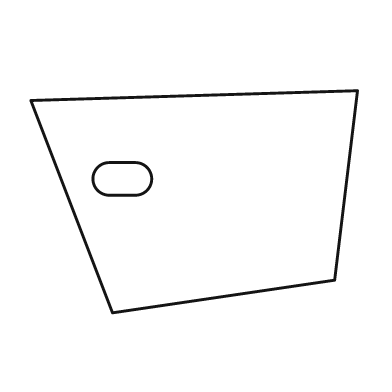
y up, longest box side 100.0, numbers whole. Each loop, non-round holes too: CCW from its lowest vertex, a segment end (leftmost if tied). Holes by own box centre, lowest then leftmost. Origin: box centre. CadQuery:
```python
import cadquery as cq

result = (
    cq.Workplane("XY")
    .moveTo(-25.0, -34.0)
    .lineTo(43.0, -24.0)
    .lineTo(50.0, 34.0)
    .lineTo(-50.0, 31.0)
    .close()
    .moveTo(-26.0, 2.0)
    .lineTo(-18.0, 2.0)
    .threePointArc((-13.0, 7.0), (-18.0, 12.0))
    .lineTo(-26.0, 12.0)
    .threePointArc((-31.0, 7.0), (-26.0, 2.0))
    .close()
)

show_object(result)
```